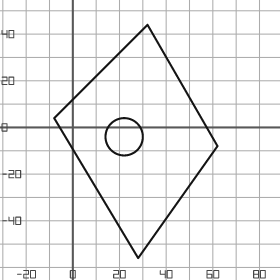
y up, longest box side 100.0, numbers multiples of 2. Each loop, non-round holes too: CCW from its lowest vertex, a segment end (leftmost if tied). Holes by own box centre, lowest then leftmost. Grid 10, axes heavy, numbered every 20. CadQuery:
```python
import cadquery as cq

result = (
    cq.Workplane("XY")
    .moveTo(28.0, -56.0)
    .lineTo(62.0, -8.0)
    .lineTo(32.0, 44.0)
    .lineTo(-8.0, 4.0)
    .close()
    .moveTo(22.0, -4.0)
    .circle(8.0)
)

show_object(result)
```